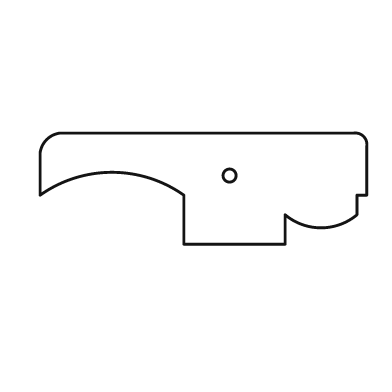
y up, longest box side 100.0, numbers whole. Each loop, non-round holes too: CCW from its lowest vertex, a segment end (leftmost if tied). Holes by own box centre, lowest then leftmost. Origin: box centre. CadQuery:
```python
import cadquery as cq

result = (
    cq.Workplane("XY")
    .moveTo(-6.0, -17.0)
    .lineTo(25.0, -17.0)
    .lineTo(25.0, -8.0)
    .threePointArc((36.0, -12.0), (47.0, -8.0))
    .lineTo(47.0, -2.0)
    .lineTo(50.0, -2.0)
    .lineTo(50.0, 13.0)
    .threePointArc((49.0, 16.0), (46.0, 17.0))
    .lineTo(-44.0, 17.0)
    .threePointArc((-48.0, 15.0), (-50.0, 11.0))
    .lineTo(-50.0, -2.0)
    .threePointArc((-28.0, 5.0), (-6.0, -2.0))
    .close()
    .moveTo(8.0, 4.0)
    .circle(2.0)
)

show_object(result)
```